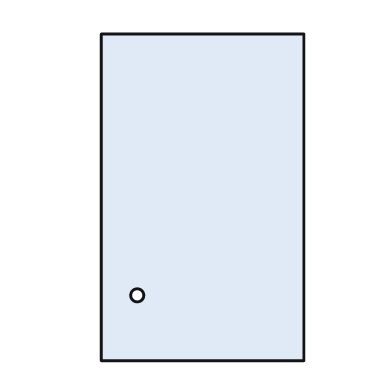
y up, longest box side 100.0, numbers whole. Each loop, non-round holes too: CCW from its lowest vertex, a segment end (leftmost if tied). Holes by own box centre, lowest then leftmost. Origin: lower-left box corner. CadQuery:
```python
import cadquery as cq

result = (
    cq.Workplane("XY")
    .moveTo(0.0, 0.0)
    .lineTo(62.0, 0.0)
    .lineTo(62.0, 100.0)
    .lineTo(0.0, 100.0)
    .close()
    .moveTo(11.0, 20.0)
    .circle(2.0)
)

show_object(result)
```